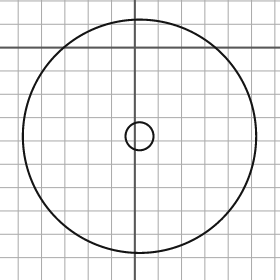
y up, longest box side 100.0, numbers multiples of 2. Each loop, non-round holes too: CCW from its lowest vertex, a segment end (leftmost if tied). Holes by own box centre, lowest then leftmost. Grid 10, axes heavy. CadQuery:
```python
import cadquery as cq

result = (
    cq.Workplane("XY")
    .moveTo(2.0, -38.0)
    .circle(50.0)
    .moveTo(2.0, -38.0)
    .circle(6.0)
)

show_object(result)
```